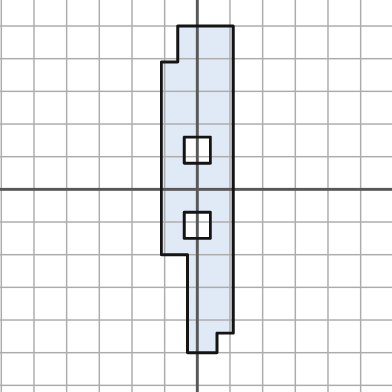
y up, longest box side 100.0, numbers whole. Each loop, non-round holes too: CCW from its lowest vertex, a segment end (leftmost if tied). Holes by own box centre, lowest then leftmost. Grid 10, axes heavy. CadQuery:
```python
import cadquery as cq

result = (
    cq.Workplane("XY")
    .moveTo(-3.0, -50.0)
    .lineTo(6.0, -50.0)
    .lineTo(6.0, -44.0)
    .lineTo(11.0, -44.0)
    .lineTo(11.0, 50.0)
    .lineTo(-6.0, 50.0)
    .lineTo(-6.0, 39.0)
    .lineTo(-11.0, 39.0)
    .lineTo(-11.0, -20.0)
    .lineTo(-3.0, -20.0)
    .close()
    .moveTo(-4.0, -15.0)
    .lineTo(4.0, -15.0)
    .lineTo(4.0, -7.0)
    .lineTo(-4.0, -7.0)
    .close()
    .moveTo(-4.0, 8.0)
    .lineTo(4.0, 8.0)
    .lineTo(4.0, 16.0)
    .lineTo(-4.0, 16.0)
    .close()
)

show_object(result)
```